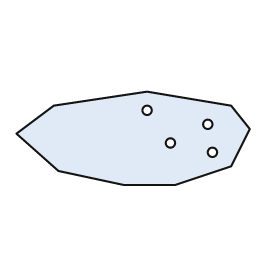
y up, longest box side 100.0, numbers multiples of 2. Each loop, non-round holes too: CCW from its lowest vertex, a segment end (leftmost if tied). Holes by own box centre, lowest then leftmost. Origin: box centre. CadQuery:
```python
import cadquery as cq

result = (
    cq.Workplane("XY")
    .moveTo(-4.0, -20.0)
    .lineTo(18.0, -20.0)
    .lineTo(42.0, -12.0)
    .lineTo(50.0, 4.0)
    .lineTo(42.0, 14.0)
    .lineTo(6.0, 20.0)
    .lineTo(-34.0, 14.0)
    .lineTo(-50.0, 2.0)
    .lineTo(-32.0, -14.0)
    .close()
    .moveTo(34.0, -6.0)
    .circle(2.0)
    .moveTo(16.0, -2.0)
    .circle(2.0)
    .moveTo(32.0, 6.0)
    .circle(2.0)
    .moveTo(6.0, 12.0)
    .circle(2.0)
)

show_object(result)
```